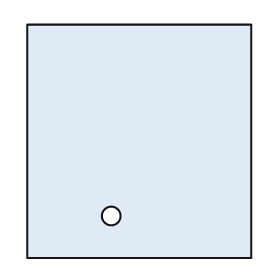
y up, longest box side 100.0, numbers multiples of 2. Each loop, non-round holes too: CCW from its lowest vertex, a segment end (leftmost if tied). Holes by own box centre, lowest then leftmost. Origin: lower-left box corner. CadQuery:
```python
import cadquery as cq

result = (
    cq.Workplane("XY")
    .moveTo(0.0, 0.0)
    .lineTo(96.0, 0.0)
    .lineTo(96.0, 100.0)
    .lineTo(0.0, 100.0)
    .close()
    .moveTo(36.0, 18.0)
    .circle(4.0)
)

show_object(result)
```